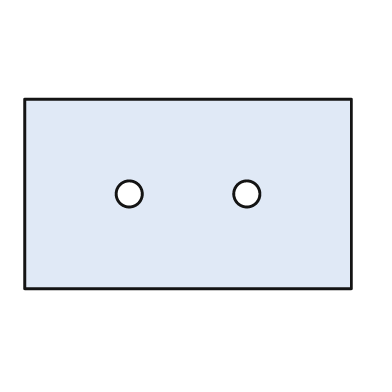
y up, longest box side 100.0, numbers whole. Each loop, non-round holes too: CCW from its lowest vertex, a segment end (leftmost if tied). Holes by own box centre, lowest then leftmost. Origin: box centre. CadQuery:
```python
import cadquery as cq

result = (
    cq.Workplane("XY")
    .moveTo(-50.0, -29.0)
    .lineTo(50.0, -29.0)
    .lineTo(50.0, 29.0)
    .lineTo(-50.0, 29.0)
    .close()
    .moveTo(-18.0, 0.0)
    .circle(4.0)
    .moveTo(18.0, 0.0)
    .circle(4.0)
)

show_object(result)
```